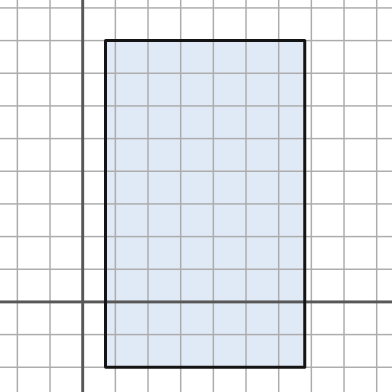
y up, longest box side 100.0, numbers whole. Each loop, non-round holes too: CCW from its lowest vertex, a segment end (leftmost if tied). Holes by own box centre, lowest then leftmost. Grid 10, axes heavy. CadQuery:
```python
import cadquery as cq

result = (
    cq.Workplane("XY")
    .moveTo(7.0, -20.0)
    .lineTo(68.0, -20.0)
    .lineTo(68.0, 80.0)
    .lineTo(7.0, 80.0)
    .close()
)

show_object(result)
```